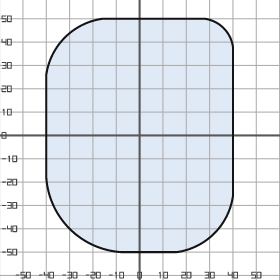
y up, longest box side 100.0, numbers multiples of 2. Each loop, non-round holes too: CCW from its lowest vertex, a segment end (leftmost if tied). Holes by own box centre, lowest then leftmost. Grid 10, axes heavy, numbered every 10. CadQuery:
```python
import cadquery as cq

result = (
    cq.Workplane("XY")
    .moveTo(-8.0, -50.0)
    .lineTo(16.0, -50.0)
    .threePointArc((32.0, -42.0), (40.0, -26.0))
    .lineTo(40.0, 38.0)
    .threePointArc((36.0, 46.0), (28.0, 50.0))
    .lineTo(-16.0, 50.0)
    .threePointArc((-32.0, 42.0), (-40.0, 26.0))
    .lineTo(-40.0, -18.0)
    .threePointArc((-30.0, -40.0), (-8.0, -50.0))
    .close()
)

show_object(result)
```